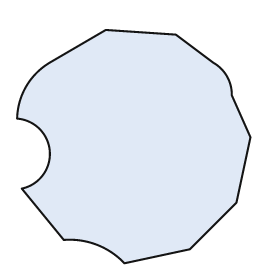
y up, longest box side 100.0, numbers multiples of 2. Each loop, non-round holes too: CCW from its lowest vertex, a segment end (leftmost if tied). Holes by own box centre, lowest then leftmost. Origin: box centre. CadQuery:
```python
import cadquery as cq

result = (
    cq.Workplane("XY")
    .moveTo(-4.0, -50.0)
    .lineTo(24.0, -44.0)
    .lineTo(44.0, -24.0)
    .lineTo(50.0, 4.0)
    .lineTo(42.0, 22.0)
    .threePointArc((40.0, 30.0), (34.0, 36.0))
    .lineTo(18.0, 48.0)
    .lineTo(-12.0, 50.0)
    .lineTo(-36.0, 36.0)
    .threePointArc((-46.0, 26.0), (-50.0, 12.0))
    .threePointArc((-36.0, -2.0), (-48.0, -18.0))
    .lineTo(-30.0, -40.0)
    .threePointArc((-16.0, -42.0), (-4.0, -50.0))
    .close()
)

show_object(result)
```